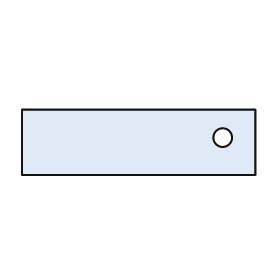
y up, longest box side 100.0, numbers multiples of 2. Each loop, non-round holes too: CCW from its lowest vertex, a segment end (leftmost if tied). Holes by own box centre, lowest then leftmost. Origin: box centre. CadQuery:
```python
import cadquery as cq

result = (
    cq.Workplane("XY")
    .moveTo(-50.0, -14.0)
    .lineTo(50.0, -14.0)
    .lineTo(50.0, 14.0)
    .lineTo(-50.0, 14.0)
    .close()
    .moveTo(36.0, 2.0)
    .circle(4.0)
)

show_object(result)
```